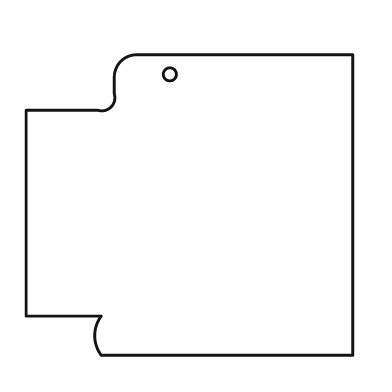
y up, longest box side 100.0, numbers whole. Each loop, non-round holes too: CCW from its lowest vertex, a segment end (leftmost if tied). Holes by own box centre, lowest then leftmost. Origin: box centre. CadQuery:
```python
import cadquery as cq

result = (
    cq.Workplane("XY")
    .moveTo(-27.0, -46.0)
    .lineTo(50.0, -46.0)
    .lineTo(50.0, 46.0)
    .lineTo(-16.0, 46.0)
    .threePointArc((-21.0, 44.0), (-23.0, 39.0))
    .lineTo(-23.0, 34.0)
    .threePointArc((-24.0, 30.0), (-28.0, 29.0))
    .lineTo(-50.0, 29.0)
    .lineTo(-50.0, -34.0)
    .lineTo(-27.0, -34.0)
    .threePointArc((-29.0, -40.0), (-27.0, -46.0))
    .close()
    .moveTo(-6.0, 40.0)
    .circle(2.0)
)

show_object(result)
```